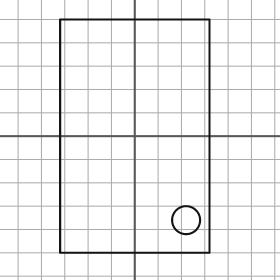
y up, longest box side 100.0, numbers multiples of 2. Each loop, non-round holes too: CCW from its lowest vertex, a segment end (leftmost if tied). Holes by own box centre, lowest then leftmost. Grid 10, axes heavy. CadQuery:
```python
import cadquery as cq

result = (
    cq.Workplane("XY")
    .moveTo(-32.0, -50.0)
    .lineTo(32.0, -50.0)
    .lineTo(32.0, 50.0)
    .lineTo(-32.0, 50.0)
    .close()
    .moveTo(22.0, -36.0)
    .circle(6.0)
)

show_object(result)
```